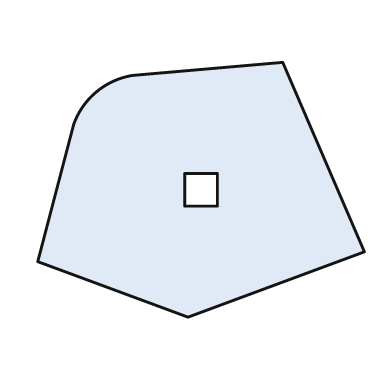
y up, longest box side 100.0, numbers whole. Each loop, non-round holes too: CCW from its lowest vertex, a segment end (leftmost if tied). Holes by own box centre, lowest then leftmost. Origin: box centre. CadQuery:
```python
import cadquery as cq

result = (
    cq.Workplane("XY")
    .moveTo(-4.0, -39.0)
    .lineTo(50.0, -19.0)
    .lineTo(25.0, 39.0)
    .lineTo(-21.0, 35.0)
    .threePointArc((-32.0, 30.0), (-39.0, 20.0))
    .lineTo(-50.0, -22.0)
    .close()
    .moveTo(-5.0, -5.0)
    .lineTo(5.0, -5.0)
    .lineTo(5.0, 5.0)
    .lineTo(-5.0, 5.0)
    .close()
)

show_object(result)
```